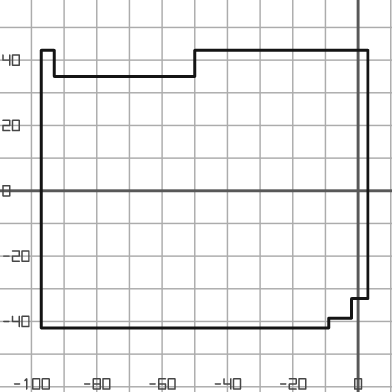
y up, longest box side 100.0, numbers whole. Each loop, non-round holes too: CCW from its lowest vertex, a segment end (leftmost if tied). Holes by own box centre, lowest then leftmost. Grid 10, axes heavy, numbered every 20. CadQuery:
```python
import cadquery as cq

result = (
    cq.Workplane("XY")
    .moveTo(-97.0, -42.0)
    .lineTo(-9.0, -42.0)
    .lineTo(-9.0, -39.0)
    .lineTo(-2.0, -39.0)
    .lineTo(-2.0, -33.0)
    .lineTo(3.0, -33.0)
    .lineTo(3.0, 43.0)
    .lineTo(-50.0, 43.0)
    .lineTo(-50.0, 35.0)
    .lineTo(-93.0, 35.0)
    .lineTo(-93.0, 43.0)
    .lineTo(-97.0, 43.0)
    .close()
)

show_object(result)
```